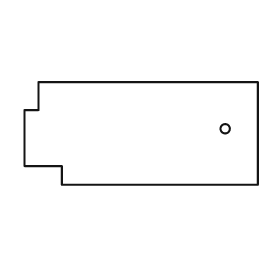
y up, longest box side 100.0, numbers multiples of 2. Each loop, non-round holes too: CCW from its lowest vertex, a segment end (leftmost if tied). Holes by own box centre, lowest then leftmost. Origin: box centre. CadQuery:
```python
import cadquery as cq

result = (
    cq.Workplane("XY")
    .moveTo(-34.0, -22.0)
    .lineTo(50.0, -22.0)
    .lineTo(50.0, 22.0)
    .lineTo(-44.0, 22.0)
    .lineTo(-44.0, 10.0)
    .lineTo(-50.0, 10.0)
    .lineTo(-50.0, -14.0)
    .lineTo(-34.0, -14.0)
    .close()
    .moveTo(36.0, 2.0)
    .circle(2.0)
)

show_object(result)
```